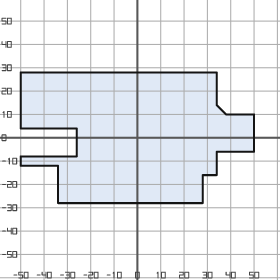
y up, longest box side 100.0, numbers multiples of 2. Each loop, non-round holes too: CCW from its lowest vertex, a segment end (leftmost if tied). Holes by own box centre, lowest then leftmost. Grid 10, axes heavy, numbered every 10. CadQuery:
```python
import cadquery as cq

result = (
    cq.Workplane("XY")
    .moveTo(-34.0, -28.0)
    .lineTo(28.0, -28.0)
    .lineTo(28.0, -16.0)
    .lineTo(34.0, -16.0)
    .lineTo(34.0, -6.0)
    .lineTo(50.0, -6.0)
    .lineTo(50.0, 10.0)
    .lineTo(38.0, 10.0)
    .lineTo(34.0, 14.0)
    .lineTo(34.0, 28.0)
    .lineTo(-50.0, 28.0)
    .lineTo(-50.0, 4.0)
    .lineTo(-26.0, 4.0)
    .lineTo(-26.0, -8.0)
    .lineTo(-50.0, -8.0)
    .lineTo(-50.0, -12.0)
    .lineTo(-34.0, -12.0)
    .close()
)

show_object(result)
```